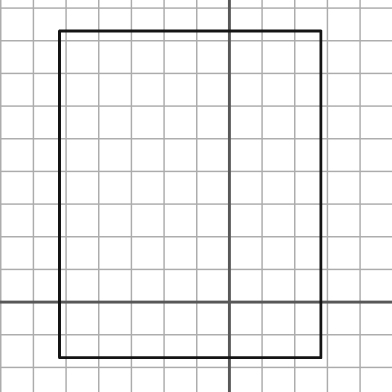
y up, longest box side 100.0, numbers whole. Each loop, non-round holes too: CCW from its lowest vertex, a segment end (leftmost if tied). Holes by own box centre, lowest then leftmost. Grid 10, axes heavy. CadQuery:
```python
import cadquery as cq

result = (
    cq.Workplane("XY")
    .moveTo(-52.0, -17.0)
    .lineTo(28.0, -17.0)
    .lineTo(28.0, 83.0)
    .lineTo(-52.0, 83.0)
    .close()
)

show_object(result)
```